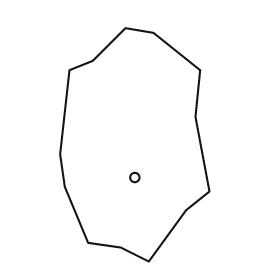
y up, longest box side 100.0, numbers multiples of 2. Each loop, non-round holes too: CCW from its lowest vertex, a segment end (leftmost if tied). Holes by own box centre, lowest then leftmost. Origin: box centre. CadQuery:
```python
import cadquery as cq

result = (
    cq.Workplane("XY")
    .moveTo(6.0, -50.0)
    .lineTo(22.0, -28.0)
    .lineTo(32.0, -20.0)
    .lineTo(26.0, 12.0)
    .lineTo(28.0, 32.0)
    .lineTo(8.0, 48.0)
    .lineTo(-4.0, 50.0)
    .lineTo(-18.0, 36.0)
    .lineTo(-28.0, 32.0)
    .lineTo(-32.0, -4.0)
    .lineTo(-30.0, -18.0)
    .lineTo(-20.0, -42.0)
    .lineTo(-6.0, -44.0)
    .close()
    .moveTo(0.0, -14.0)
    .circle(2.0)
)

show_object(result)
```